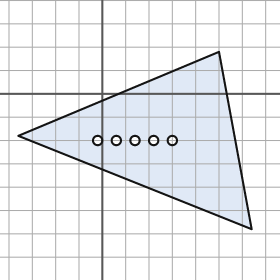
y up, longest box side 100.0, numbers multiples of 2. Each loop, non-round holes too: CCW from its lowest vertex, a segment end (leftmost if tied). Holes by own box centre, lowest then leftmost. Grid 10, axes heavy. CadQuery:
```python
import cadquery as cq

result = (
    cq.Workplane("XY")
    .moveTo(64.0, -58.0)
    .lineTo(50.0, 18.0)
    .lineTo(-36.0, -18.0)
    .close()
    .moveTo(-2.0, -20.0)
    .circle(2.0)
    .moveTo(6.0, -20.0)
    .circle(2.0)
    .moveTo(14.0, -20.0)
    .circle(2.0)
    .moveTo(22.0, -20.0)
    .circle(2.0)
    .moveTo(30.0, -20.0)
    .circle(2.0)
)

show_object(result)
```